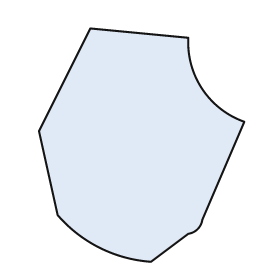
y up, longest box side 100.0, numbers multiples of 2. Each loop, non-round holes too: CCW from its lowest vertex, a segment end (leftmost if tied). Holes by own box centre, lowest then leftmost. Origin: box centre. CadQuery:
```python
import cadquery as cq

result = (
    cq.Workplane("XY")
    .moveTo(4.0, -50.0)
    .lineTo(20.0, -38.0)
    .threePointArc((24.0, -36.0), (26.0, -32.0))
    .lineTo(44.0, 10.0)
    .threePointArc((26.0, 24.0), (20.0, 46.0))
    .lineTo(-22.0, 50.0)
    .lineTo(-44.0, 6.0)
    .lineTo(-36.0, -30.0)
    .threePointArc((-18.0, -44.0), (4.0, -50.0))
    .close()
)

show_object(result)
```